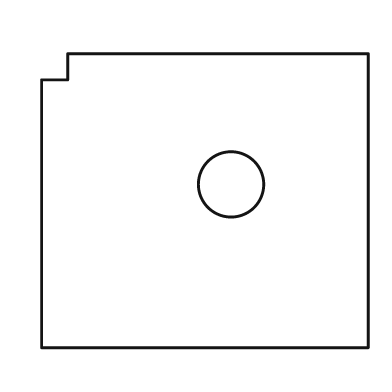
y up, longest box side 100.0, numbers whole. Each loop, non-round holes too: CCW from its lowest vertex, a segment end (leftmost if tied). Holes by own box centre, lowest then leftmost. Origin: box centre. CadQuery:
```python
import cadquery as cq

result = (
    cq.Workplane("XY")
    .moveTo(-50.0, -45.0)
    .lineTo(50.0, -45.0)
    .lineTo(50.0, 45.0)
    .lineTo(-42.0, 45.0)
    .lineTo(-42.0, 37.0)
    .lineTo(-50.0, 37.0)
    .close()
    .moveTo(8.0, 5.0)
    .circle(10.0)
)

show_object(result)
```